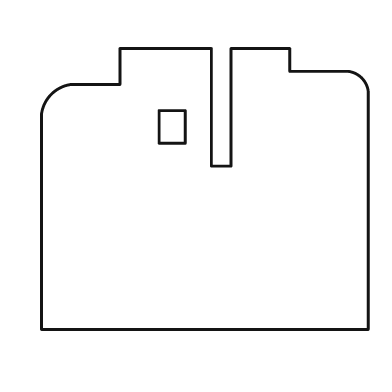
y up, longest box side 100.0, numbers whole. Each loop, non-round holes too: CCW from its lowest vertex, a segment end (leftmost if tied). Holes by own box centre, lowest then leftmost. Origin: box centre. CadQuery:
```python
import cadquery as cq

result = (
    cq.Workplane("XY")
    .moveTo(-50.0, -43.0)
    .lineTo(50.0, -43.0)
    .lineTo(50.0, 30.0)
    .threePointArc((48.0, 34.0), (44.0, 36.0))
    .lineTo(26.0, 36.0)
    .lineTo(26.0, 43.0)
    .lineTo(8.0, 43.0)
    .lineTo(8.0, 7.0)
    .lineTo(2.0, 7.0)
    .lineTo(2.0, 43.0)
    .lineTo(-26.0, 43.0)
    .lineTo(-26.0, 32.0)
    .lineTo(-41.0, 32.0)
    .threePointArc((-47.0, 29.0), (-50.0, 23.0))
    .close()
    .moveTo(-14.0, 14.0)
    .lineTo(-6.0, 14.0)
    .lineTo(-6.0, 24.0)
    .lineTo(-14.0, 24.0)
    .close()
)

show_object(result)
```